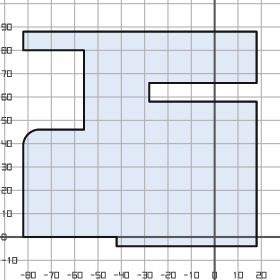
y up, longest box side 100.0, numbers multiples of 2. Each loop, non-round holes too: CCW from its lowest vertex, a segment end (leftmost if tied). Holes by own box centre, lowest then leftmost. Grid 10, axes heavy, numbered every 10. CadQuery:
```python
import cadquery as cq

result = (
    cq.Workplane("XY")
    .moveTo(-42.0, -4.0)
    .lineTo(18.0, -4.0)
    .lineTo(18.0, 58.0)
    .lineTo(-28.0, 58.0)
    .lineTo(-28.0, 66.0)
    .lineTo(18.0, 66.0)
    .lineTo(18.0, 88.0)
    .lineTo(-82.0, 88.0)
    .lineTo(-82.0, 80.0)
    .lineTo(-56.0, 80.0)
    .lineTo(-56.0, 46.0)
    .lineTo(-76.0, 46.0)
    .threePointArc((-80.0, 44.0), (-82.0, 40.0))
    .lineTo(-82.0, 0.0)
    .lineTo(-42.0, 0.0)
    .close()
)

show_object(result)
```